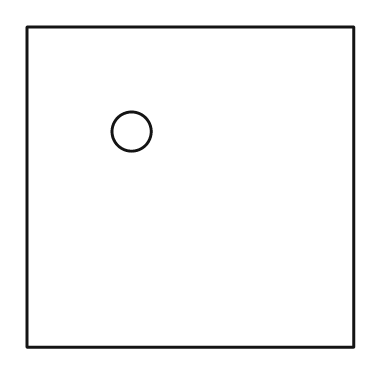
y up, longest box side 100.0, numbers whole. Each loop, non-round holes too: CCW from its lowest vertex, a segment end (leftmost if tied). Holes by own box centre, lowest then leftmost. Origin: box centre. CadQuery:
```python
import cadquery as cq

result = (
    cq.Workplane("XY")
    .moveTo(-50.0, -49.0)
    .lineTo(50.0, -49.0)
    .lineTo(50.0, 49.0)
    .lineTo(-50.0, 49.0)
    .close()
    .moveTo(-18.0, 17.0)
    .circle(6.0)
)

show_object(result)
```